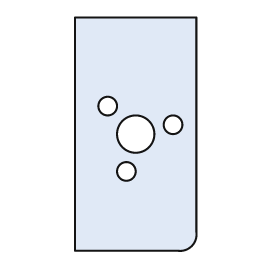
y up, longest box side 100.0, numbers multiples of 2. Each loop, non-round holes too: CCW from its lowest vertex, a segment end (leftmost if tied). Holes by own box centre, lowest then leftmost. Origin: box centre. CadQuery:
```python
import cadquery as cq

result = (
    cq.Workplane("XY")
    .moveTo(-26.0, -50.0)
    .lineTo(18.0, -50.0)
    .threePointArc((24.0, -48.0), (26.0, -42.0))
    .lineTo(26.0, 50.0)
    .lineTo(-26.0, 50.0)
    .close()
    .moveTo(-4.0, -16.0)
    .circle(4.0)
    .moveTo(0.0, 0.0)
    .circle(8.0)
    .moveTo(16.0, 4.0)
    .circle(4.0)
    .moveTo(-12.0, 12.0)
    .circle(4.0)
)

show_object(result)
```